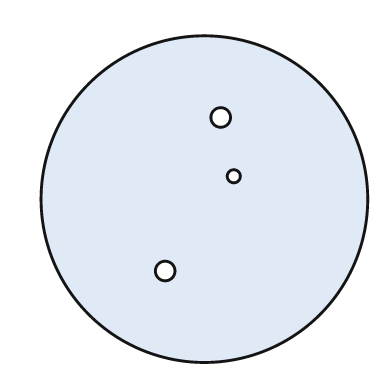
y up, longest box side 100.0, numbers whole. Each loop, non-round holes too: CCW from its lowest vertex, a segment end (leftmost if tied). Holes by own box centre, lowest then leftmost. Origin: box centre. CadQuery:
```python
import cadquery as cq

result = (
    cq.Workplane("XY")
    .moveTo(0.0, 0.0)
    .circle(50.0)
    .moveTo(-12.0, -22.0)
    .circle(3.0)
    .moveTo(9.0, 7.0)
    .circle(2.0)
    .moveTo(5.0, 25.0)
    .circle(3.0)
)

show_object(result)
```